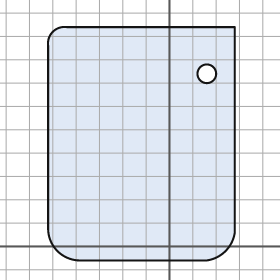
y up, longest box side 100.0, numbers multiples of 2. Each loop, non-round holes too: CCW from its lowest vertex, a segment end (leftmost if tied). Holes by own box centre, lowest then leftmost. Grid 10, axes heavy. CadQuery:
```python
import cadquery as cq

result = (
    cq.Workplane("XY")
    .moveTo(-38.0, -6.0)
    .lineTo(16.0, -6.0)
    .threePointArc((24.0, -2.0), (28.0, 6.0))
    .lineTo(28.0, 94.0)
    .lineTo(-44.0, 94.0)
    .threePointArc((-50.0, 92.0), (-52.0, 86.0))
    .lineTo(-52.0, 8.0)
    .threePointArc((-48.0, -2.0), (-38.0, -6.0))
    .close()
    .moveTo(16.0, 74.0)
    .circle(4.0)
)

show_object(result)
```